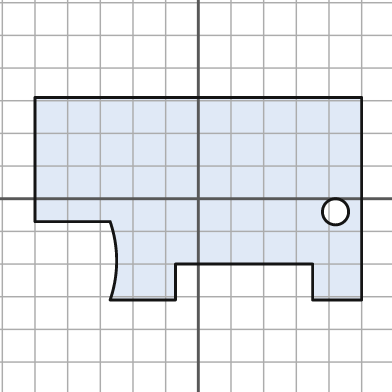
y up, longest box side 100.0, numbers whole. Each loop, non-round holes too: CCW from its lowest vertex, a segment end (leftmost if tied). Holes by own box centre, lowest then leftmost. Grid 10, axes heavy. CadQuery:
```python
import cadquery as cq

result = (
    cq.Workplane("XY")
    .moveTo(-27.0, -31.0)
    .lineTo(-7.0, -31.0)
    .lineTo(-7.0, -20.0)
    .lineTo(35.0, -20.0)
    .lineTo(35.0, -31.0)
    .lineTo(50.0, -31.0)
    .lineTo(50.0, 31.0)
    .lineTo(-50.0, 31.0)
    .lineTo(-50.0, -7.0)
    .lineTo(-27.0, -7.0)
    .threePointArc((-25.0, -19.0), (-27.0, -31.0))
    .close()
    .moveTo(42.0, -4.0)
    .circle(4.0)
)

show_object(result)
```